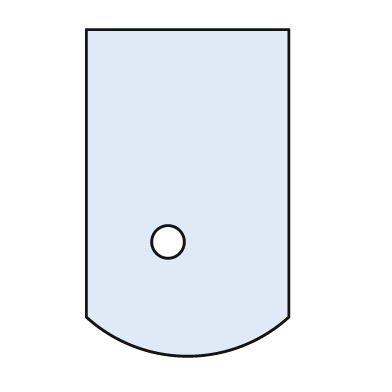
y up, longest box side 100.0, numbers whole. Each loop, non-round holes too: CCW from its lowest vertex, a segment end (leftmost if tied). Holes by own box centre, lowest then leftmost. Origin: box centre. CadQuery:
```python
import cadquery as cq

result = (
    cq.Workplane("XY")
    .moveTo(-31.0, -38.0)
    .threePointArc((0.0, -50.0), (31.0, -38.0))
    .lineTo(31.0, 50.0)
    .lineTo(-31.0, 50.0)
    .close()
    .moveTo(-6.0, -15.0)
    .circle(5.0)
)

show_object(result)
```